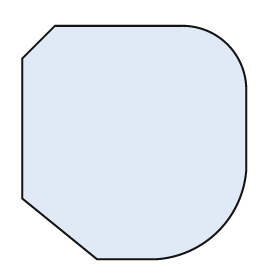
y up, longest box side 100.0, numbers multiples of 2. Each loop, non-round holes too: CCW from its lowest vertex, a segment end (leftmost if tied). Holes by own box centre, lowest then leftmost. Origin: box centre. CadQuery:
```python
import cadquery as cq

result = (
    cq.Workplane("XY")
    .moveTo(-16.0, -50.0)
    .lineTo(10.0, -50.0)
    .threePointArc((36.0, -38.0), (48.0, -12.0))
    .lineTo(48.0, 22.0)
    .threePointArc((40.0, 42.0), (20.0, 50.0))
    .lineTo(-34.0, 50.0)
    .lineTo(-48.0, 36.0)
    .lineTo(-48.0, -24.0)
    .close()
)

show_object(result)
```